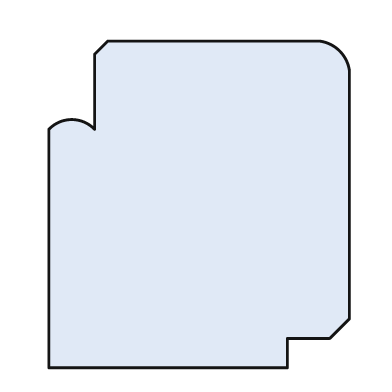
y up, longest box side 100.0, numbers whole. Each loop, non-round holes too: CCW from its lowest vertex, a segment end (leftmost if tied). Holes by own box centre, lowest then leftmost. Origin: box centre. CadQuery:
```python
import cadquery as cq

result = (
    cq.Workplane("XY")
    .moveTo(-46.0, -50.0)
    .lineTo(27.0, -50.0)
    .lineTo(27.0, -41.0)
    .lineTo(40.0, -41.0)
    .lineTo(46.0, -35.0)
    .lineTo(46.0, 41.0)
    .threePointArc((43.0, 47.0), (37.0, 50.0))
    .lineTo(-28.0, 50.0)
    .lineTo(-32.0, 46.0)
    .lineTo(-32.0, 23.0)
    .threePointArc((-39.0, 26.0), (-46.0, 23.0))
    .close()
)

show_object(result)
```